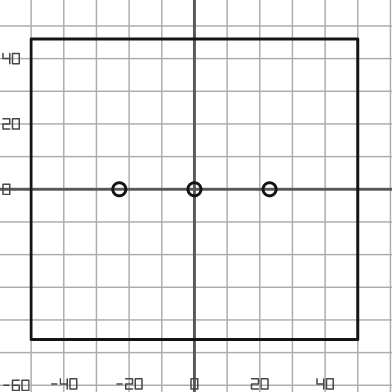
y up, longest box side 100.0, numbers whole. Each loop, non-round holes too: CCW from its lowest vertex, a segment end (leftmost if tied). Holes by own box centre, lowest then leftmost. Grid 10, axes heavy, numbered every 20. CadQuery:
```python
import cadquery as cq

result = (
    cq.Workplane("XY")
    .moveTo(-50.0, -46.0)
    .lineTo(50.0, -46.0)
    .lineTo(50.0, 46.0)
    .lineTo(-50.0, 46.0)
    .close()
    .moveTo(-23.0, 0.0)
    .circle(2.0)
    .moveTo(0.0, 0.0)
    .circle(2.0)
    .moveTo(23.0, 0.0)
    .circle(2.0)
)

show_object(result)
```